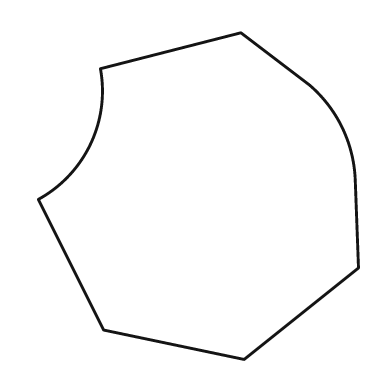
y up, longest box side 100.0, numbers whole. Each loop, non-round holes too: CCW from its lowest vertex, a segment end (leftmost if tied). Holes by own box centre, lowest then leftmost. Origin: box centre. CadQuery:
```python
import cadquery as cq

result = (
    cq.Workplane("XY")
    .moveTo(14.0, -50.0)
    .lineTo(49.0, -22.0)
    .lineTo(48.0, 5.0)
    .threePointArc((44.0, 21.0), (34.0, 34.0))
    .lineTo(13.0, 50.0)
    .lineTo(-30.0, 39.0)
    .threePointArc((-33.0, 16.0), (-49.0, -1.0))
    .lineTo(-29.0, -41.0)
    .close()
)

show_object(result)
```